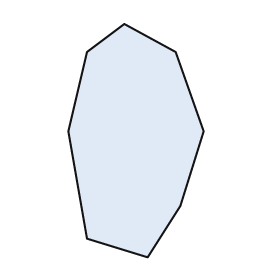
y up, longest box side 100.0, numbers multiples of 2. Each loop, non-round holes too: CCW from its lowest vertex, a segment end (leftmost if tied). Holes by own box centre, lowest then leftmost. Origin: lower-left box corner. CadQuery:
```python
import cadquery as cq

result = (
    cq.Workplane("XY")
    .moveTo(34.0, 0.0)
    .lineTo(48.0, 22.0)
    .lineTo(58.0, 54.0)
    .lineTo(46.0, 88.0)
    .lineTo(24.0, 100.0)
    .lineTo(8.0, 88.0)
    .lineTo(0.0, 54.0)
    .lineTo(8.0, 8.0)
    .close()
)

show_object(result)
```